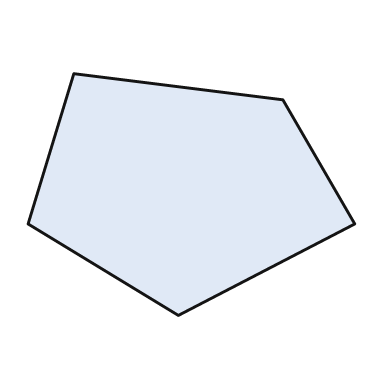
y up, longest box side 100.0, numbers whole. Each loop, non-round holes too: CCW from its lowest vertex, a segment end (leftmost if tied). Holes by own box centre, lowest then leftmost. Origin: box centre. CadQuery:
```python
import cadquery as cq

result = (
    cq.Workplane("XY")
    .moveTo(-4.0, -37.0)
    .lineTo(50.0, -9.0)
    .lineTo(28.0, 29.0)
    .lineTo(-36.0, 37.0)
    .lineTo(-50.0, -9.0)
    .close()
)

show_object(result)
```